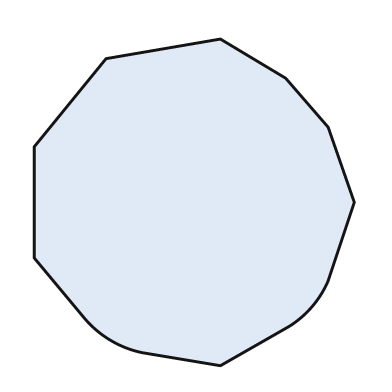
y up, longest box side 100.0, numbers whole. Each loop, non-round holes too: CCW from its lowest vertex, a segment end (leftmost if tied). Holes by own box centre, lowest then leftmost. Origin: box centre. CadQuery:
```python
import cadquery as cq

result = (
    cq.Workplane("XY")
    .moveTo(8.0, -50.0)
    .lineTo(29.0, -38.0)
    .threePointArc((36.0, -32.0), (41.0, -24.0))
    .lineTo(49.0, 0.0)
    .lineTo(41.0, 23.0)
    .lineTo(28.0, 38.0)
    .lineTo(8.0, 50.0)
    .lineTo(-27.0, 44.0)
    .lineTo(-49.0, 17.0)
    .lineTo(-49.0, -17.0)
    .lineTo(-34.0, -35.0)
    .threePointArc((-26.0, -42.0), (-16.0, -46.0))
    .close()
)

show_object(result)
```